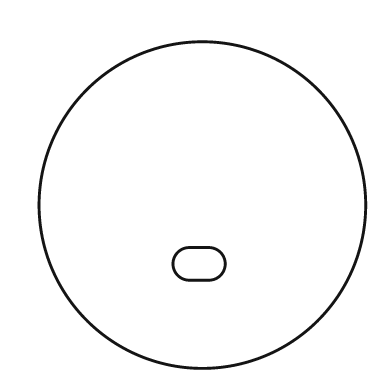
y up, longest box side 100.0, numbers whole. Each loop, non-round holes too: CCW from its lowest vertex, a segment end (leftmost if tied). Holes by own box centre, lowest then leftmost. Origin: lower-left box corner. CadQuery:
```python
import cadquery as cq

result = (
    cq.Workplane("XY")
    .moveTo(50.0, 50.0)
    .circle(50.0)
    .moveTo(46.0, 27.0)
    .lineTo(52.0, 27.0)
    .threePointArc((57.0, 32.0), (52.0, 37.0))
    .lineTo(46.0, 37.0)
    .threePointArc((41.0, 32.0), (46.0, 27.0))
    .close()
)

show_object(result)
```